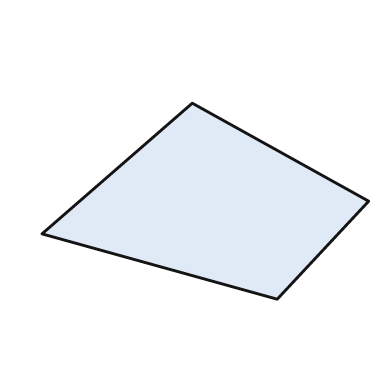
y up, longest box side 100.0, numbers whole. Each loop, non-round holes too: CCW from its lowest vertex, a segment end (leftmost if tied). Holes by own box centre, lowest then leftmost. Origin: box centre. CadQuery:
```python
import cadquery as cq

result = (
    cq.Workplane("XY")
    .moveTo(22.0, -30.0)
    .lineTo(50.0, 0.0)
    .lineTo(-4.0, 30.0)
    .lineTo(-50.0, -10.0)
    .close()
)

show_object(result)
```